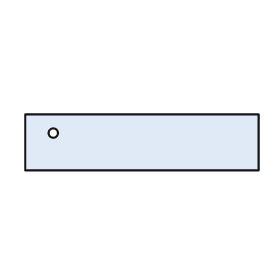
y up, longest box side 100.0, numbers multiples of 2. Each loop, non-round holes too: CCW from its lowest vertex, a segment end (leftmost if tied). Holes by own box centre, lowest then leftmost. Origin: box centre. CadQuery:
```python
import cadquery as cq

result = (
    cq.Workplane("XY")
    .moveTo(-50.0, -12.0)
    .lineTo(50.0, -12.0)
    .lineTo(50.0, 12.0)
    .lineTo(-50.0, 12.0)
    .close()
    .moveTo(-38.0, 4.0)
    .circle(2.0)
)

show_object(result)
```